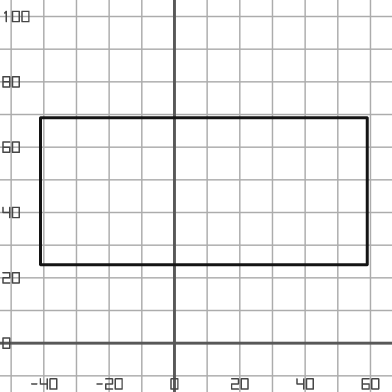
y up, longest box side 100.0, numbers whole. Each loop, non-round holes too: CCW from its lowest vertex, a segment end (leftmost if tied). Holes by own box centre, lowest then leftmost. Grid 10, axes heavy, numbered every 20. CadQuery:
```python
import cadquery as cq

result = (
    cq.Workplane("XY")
    .moveTo(-41.0, 24.0)
    .lineTo(59.0, 24.0)
    .lineTo(59.0, 69.0)
    .lineTo(-41.0, 69.0)
    .close()
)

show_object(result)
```